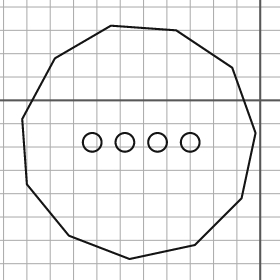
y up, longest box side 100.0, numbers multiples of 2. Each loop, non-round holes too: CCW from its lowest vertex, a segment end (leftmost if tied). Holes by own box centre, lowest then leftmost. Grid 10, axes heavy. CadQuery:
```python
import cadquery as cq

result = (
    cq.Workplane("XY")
    .moveTo(-56.0, -68.0)
    .lineTo(-28.0, -62.0)
    .lineTo(-8.0, -42.0)
    .lineTo(-2.0, -14.0)
    .lineTo(-12.0, 14.0)
    .lineTo(-36.0, 30.0)
    .lineTo(-64.0, 32.0)
    .lineTo(-88.0, 18.0)
    .lineTo(-102.0, -8.0)
    .lineTo(-100.0, -36.0)
    .lineTo(-82.0, -58.0)
    .close()
    .moveTo(-72.0, -18.0)
    .circle(4.0)
    .moveTo(-58.0, -18.0)
    .circle(4.0)
    .moveTo(-44.0, -18.0)
    .circle(4.0)
    .moveTo(-30.0, -18.0)
    .circle(4.0)
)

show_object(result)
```